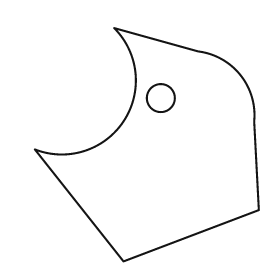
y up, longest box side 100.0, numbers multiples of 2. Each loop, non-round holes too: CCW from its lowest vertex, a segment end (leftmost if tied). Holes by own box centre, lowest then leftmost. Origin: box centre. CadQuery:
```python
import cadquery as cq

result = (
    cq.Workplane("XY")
    .moveTo(-10.0, -50.0)
    .lineTo(48.0, -28.0)
    .lineTo(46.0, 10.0)
    .threePointArc((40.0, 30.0), (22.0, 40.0))
    .lineTo(-14.0, 50.0)
    .threePointArc((-10.0, 10.0), (-48.0, -2.0))
    .close()
    .moveTo(6.0, 20.0)
    .circle(6.0)
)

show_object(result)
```